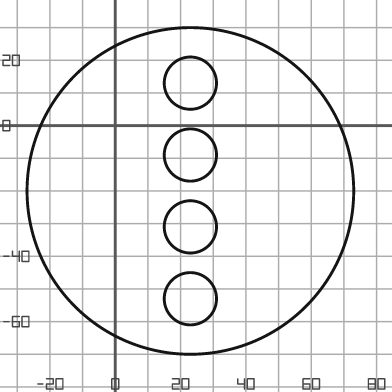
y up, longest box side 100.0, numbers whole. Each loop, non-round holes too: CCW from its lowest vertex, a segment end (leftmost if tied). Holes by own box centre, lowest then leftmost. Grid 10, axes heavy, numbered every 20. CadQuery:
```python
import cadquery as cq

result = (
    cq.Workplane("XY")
    .moveTo(23.0, -20.0)
    .circle(50.0)
    .moveTo(23.0, -53.0)
    .circle(8.0)
    .moveTo(23.0, -31.0)
    .circle(8.0)
    .moveTo(23.0, -9.0)
    .circle(8.0)
    .moveTo(23.0, 13.0)
    .circle(8.0)
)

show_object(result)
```